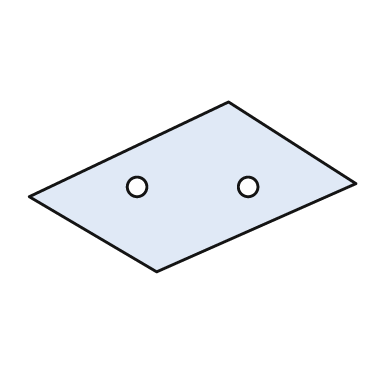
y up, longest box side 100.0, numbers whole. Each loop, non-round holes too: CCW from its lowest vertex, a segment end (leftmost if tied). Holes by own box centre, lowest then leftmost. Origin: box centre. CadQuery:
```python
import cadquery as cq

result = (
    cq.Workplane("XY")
    .moveTo(-11.0, -26.0)
    .lineTo(50.0, 1.0)
    .lineTo(11.0, 26.0)
    .lineTo(-50.0, -3.0)
    .close()
    .moveTo(-17.0, 0.0)
    .circle(3.0)
    .moveTo(17.0, 0.0)
    .circle(3.0)
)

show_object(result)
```